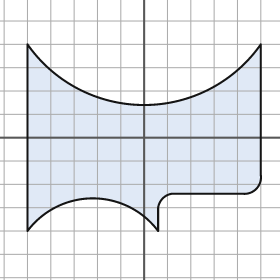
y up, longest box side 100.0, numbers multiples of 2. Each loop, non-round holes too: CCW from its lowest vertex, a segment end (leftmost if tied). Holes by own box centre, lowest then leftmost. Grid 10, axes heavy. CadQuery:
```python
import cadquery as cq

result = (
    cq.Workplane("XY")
    .moveTo(-50.0, -40.0)
    .threePointArc((-22.0, -26.0), (6.0, -40.0))
    .lineTo(6.0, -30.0)
    .threePointArc((8.0, -26.0), (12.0, -24.0))
    .lineTo(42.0, -24.0)
    .threePointArc((48.0, -22.0), (50.0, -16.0))
    .lineTo(50.0, 40.0)
    .threePointArc((0.0, 14.0), (-50.0, 40.0))
    .close()
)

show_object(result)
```